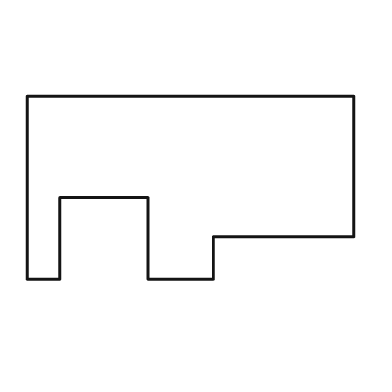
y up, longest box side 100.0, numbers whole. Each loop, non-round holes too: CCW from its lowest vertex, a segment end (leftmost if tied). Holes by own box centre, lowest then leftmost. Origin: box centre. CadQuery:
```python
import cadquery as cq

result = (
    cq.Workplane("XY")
    .moveTo(-50.0, -28.0)
    .lineTo(-40.0, -28.0)
    .lineTo(-40.0, -3.0)
    .lineTo(-13.0, -3.0)
    .lineTo(-13.0, -28.0)
    .lineTo(7.0, -28.0)
    .lineTo(7.0, -15.0)
    .lineTo(50.0, -15.0)
    .lineTo(50.0, 28.0)
    .lineTo(-50.0, 28.0)
    .close()
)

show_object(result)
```